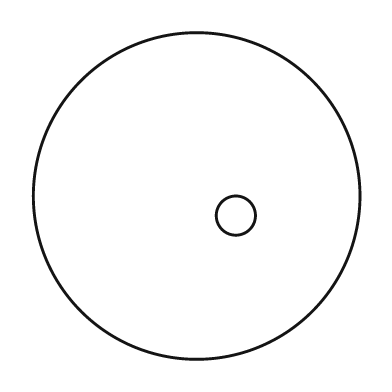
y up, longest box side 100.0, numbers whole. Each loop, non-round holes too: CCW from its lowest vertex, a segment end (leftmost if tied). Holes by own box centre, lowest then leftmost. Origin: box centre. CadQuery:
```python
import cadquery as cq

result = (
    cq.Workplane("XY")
    .moveTo(0.0, 0.0)
    .circle(50.0)
    .moveTo(12.0, -6.0)
    .circle(6.0)
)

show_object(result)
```